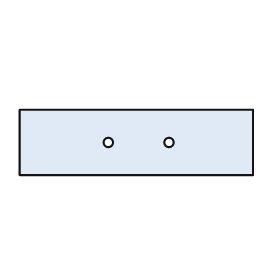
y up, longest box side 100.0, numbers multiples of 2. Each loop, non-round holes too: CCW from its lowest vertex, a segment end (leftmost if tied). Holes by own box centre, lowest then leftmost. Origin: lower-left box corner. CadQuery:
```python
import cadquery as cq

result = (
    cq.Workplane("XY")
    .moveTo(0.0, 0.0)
    .lineTo(100.0, 0.0)
    .lineTo(100.0, 28.0)
    .lineTo(0.0, 28.0)
    .close()
    .moveTo(38.0, 14.0)
    .circle(2.0)
    .moveTo(64.0, 14.0)
    .circle(2.0)
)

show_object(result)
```